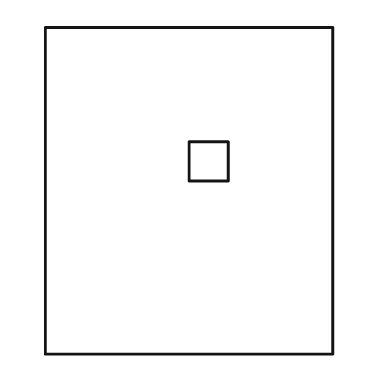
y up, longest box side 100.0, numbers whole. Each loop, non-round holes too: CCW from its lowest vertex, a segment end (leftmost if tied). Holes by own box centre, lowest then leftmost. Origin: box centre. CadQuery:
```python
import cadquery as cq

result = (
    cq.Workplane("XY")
    .moveTo(-44.0, -50.0)
    .lineTo(44.0, -50.0)
    .lineTo(44.0, 50.0)
    .lineTo(-44.0, 50.0)
    .close()
    .moveTo(0.0, 3.0)
    .lineTo(12.0, 3.0)
    .lineTo(12.0, 15.0)
    .lineTo(0.0, 15.0)
    .close()
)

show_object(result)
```